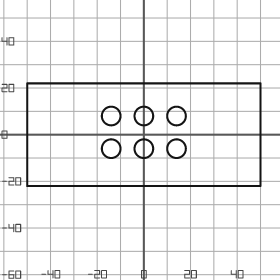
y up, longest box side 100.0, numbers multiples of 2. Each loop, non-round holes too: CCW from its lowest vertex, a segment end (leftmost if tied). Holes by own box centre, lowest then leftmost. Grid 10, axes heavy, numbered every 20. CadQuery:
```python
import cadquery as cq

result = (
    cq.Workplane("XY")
    .moveTo(-50.0, -22.0)
    .lineTo(50.0, -22.0)
    .lineTo(50.0, 22.0)
    .lineTo(-50.0, 22.0)
    .close()
    .moveTo(-14.0, -6.0)
    .circle(4.0)
    .moveTo(0.0, -6.0)
    .circle(4.0)
    .moveTo(14.0, -6.0)
    .circle(4.0)
    .moveTo(-14.0, 8.0)
    .circle(4.0)
    .moveTo(0.0, 8.0)
    .circle(4.0)
    .moveTo(14.0, 8.0)
    .circle(4.0)
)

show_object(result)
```